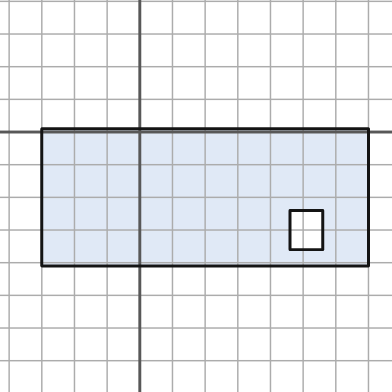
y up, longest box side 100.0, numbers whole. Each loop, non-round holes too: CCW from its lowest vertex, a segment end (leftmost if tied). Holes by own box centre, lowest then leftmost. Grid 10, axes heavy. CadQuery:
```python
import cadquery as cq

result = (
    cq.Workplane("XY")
    .moveTo(-30.0, -41.0)
    .lineTo(70.0, -41.0)
    .lineTo(70.0, 1.0)
    .lineTo(-30.0, 1.0)
    .close()
    .moveTo(46.0, -36.0)
    .lineTo(56.0, -36.0)
    .lineTo(56.0, -24.0)
    .lineTo(46.0, -24.0)
    .close()
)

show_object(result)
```